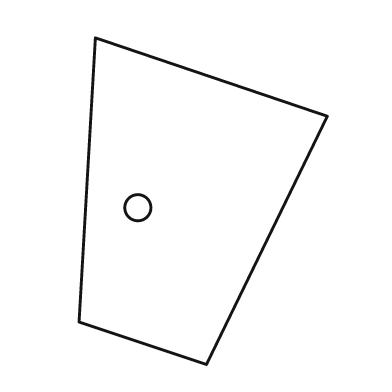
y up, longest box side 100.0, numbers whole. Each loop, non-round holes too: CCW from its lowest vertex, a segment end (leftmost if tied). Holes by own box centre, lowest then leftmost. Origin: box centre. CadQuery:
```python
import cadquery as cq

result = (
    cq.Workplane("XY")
    .moveTo(1.0, -50.0)
    .lineTo(38.0, 26.0)
    .lineTo(-33.0, 50.0)
    .lineTo(-38.0, -37.0)
    .close()
    .moveTo(-20.0, -2.0)
    .circle(4.0)
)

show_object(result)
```